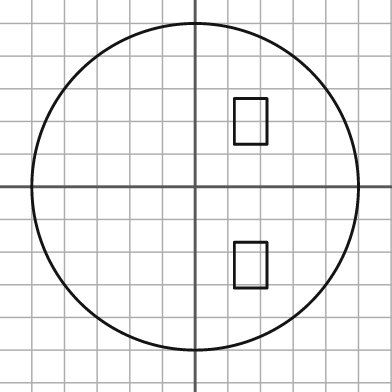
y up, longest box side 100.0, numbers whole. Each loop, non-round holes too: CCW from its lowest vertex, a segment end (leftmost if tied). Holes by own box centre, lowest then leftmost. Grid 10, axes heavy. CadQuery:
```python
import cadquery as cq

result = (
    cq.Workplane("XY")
    .moveTo(0.0, 0.0)
    .circle(50.0)
    .moveTo(12.0, -31.0)
    .lineTo(22.0, -31.0)
    .lineTo(22.0, -17.0)
    .lineTo(12.0, -17.0)
    .close()
    .moveTo(12.0, 13.0)
    .lineTo(22.0, 13.0)
    .lineTo(22.0, 27.0)
    .lineTo(12.0, 27.0)
    .close()
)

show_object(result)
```